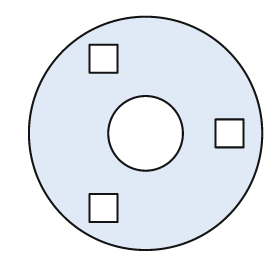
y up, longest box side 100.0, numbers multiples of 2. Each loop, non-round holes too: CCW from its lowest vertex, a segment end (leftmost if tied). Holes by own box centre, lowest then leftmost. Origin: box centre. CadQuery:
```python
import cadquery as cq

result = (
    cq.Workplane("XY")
    .moveTo(0.0, 0.0)
    .circle(50.0)
    .moveTo(-24.0, -38.0)
    .lineTo(-12.0, -38.0)
    .lineTo(-12.0, -26.0)
    .lineTo(-24.0, -26.0)
    .close()
    .moveTo(0.0, 0.0)
    .circle(16.0)
    .moveTo(30.0, -6.0)
    .lineTo(42.0, -6.0)
    .lineTo(42.0, 6.0)
    .lineTo(30.0, 6.0)
    .close()
    .moveTo(-24.0, 26.0)
    .lineTo(-12.0, 26.0)
    .lineTo(-12.0, 38.0)
    .lineTo(-24.0, 38.0)
    .close()
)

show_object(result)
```